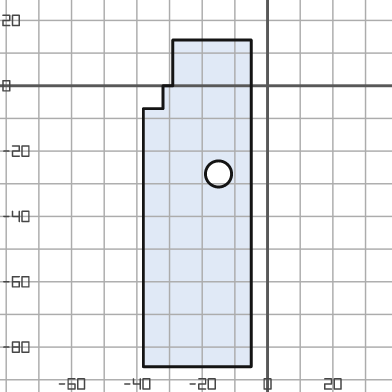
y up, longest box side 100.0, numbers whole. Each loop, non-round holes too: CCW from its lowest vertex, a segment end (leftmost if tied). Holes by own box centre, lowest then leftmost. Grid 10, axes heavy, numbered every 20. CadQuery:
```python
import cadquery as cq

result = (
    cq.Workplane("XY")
    .moveTo(-38.0, -86.0)
    .lineTo(-5.0, -86.0)
    .lineTo(-5.0, 14.0)
    .lineTo(-29.0, 14.0)
    .lineTo(-29.0, 0.0)
    .lineTo(-32.0, 0.0)
    .lineTo(-32.0, -7.0)
    .lineTo(-38.0, -7.0)
    .close()
    .moveTo(-15.0, -27.0)
    .circle(4.0)
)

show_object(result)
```